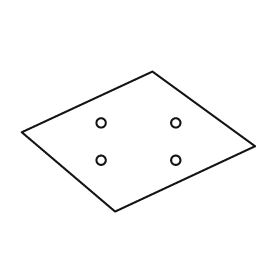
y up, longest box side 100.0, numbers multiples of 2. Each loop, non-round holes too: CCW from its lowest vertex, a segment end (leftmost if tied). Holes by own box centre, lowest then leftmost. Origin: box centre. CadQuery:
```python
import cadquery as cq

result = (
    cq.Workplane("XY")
    .moveTo(-10.0, -30.0)
    .lineTo(50.0, -2.0)
    .lineTo(6.0, 30.0)
    .lineTo(-50.0, 4.0)
    .close()
    .moveTo(-16.0, -8.0)
    .circle(2.0)
    .moveTo(16.0, -8.0)
    .circle(2.0)
    .moveTo(-16.0, 8.0)
    .circle(2.0)
    .moveTo(16.0, 8.0)
    .circle(2.0)
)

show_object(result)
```